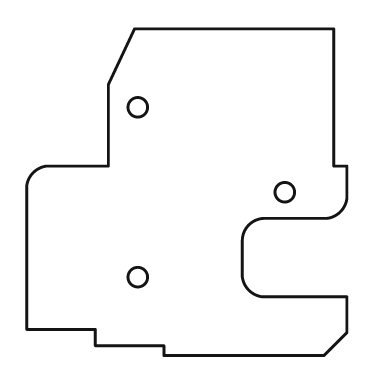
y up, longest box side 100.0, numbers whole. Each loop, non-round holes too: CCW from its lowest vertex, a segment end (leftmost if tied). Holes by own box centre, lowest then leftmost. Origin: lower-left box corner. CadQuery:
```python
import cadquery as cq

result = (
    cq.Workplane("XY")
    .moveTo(42.0, 0.0)
    .lineTo(91.0, 0.0)
    .lineTo(98.0, 7.0)
    .lineTo(98.0, 18.0)
    .lineTo(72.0, 18.0)
    .threePointArc((68.0, 20.0), (66.0, 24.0))
    .lineTo(66.0, 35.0)
    .threePointArc((68.0, 40.0), (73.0, 42.0))
    .lineTo(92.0, 42.0)
    .threePointArc((96.0, 44.0), (98.0, 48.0))
    .lineTo(98.0, 58.0)
    .lineTo(94.0, 58.0)
    .lineTo(94.0, 100.0)
    .lineTo(33.0, 100.0)
    .lineTo(25.0, 83.0)
    .lineTo(25.0, 58.0)
    .lineTo(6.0, 58.0)
    .threePointArc((2.0, 56.0), (0.0, 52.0))
    .lineTo(0.0, 8.0)
    .lineTo(21.0, 8.0)
    .lineTo(21.0, 3.0)
    .lineTo(42.0, 3.0)
    .close()
    .moveTo(34.0, 24.0)
    .circle(3.0)
    .moveTo(79.0, 50.0)
    .circle(3.0)
    .moveTo(34.0, 76.0)
    .circle(3.0)
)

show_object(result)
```